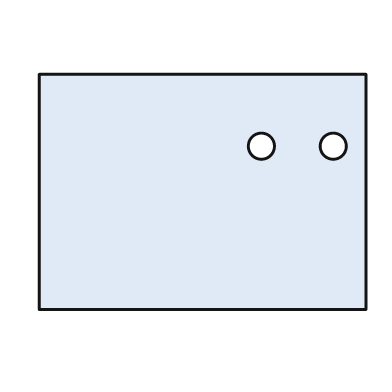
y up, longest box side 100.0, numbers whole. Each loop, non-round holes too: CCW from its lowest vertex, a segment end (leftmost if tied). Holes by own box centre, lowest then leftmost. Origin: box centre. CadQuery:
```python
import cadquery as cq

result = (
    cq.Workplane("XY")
    .moveTo(-50.0, -36.0)
    .lineTo(50.0, -36.0)
    .lineTo(50.0, 36.0)
    .lineTo(-50.0, 36.0)
    .close()
    .moveTo(18.0, 14.0)
    .circle(4.0)
    .moveTo(40.0, 14.0)
    .circle(4.0)
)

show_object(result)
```